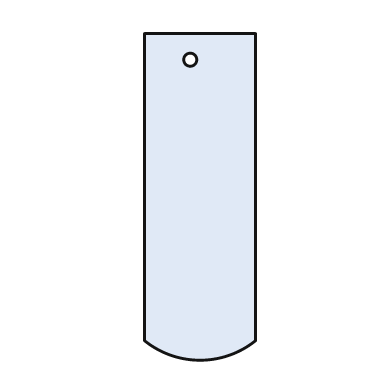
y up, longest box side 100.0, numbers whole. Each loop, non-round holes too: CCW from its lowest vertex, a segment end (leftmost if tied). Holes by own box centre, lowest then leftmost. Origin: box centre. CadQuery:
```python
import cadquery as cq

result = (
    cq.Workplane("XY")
    .moveTo(-17.0, -44.0)
    .threePointArc((0.0, -50.0), (17.0, -44.0))
    .lineTo(17.0, 50.0)
    .lineTo(-17.0, 50.0)
    .close()
    .moveTo(-3.0, 42.0)
    .circle(2.0)
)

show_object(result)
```